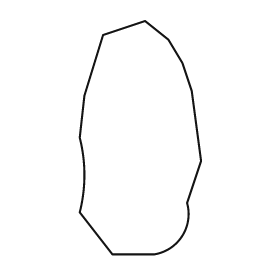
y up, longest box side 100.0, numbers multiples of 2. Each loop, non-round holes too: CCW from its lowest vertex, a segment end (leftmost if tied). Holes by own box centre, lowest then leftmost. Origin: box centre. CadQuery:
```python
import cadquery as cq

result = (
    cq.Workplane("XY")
    .moveTo(-12.0, -50.0)
    .lineTo(6.0, -50.0)
    .threePointArc((18.0, -42.0), (20.0, -28.0))
    .lineTo(26.0, -10.0)
    .lineTo(22.0, 20.0)
    .lineTo(18.0, 32.0)
    .lineTo(12.0, 42.0)
    .lineTo(2.0, 50.0)
    .lineTo(-16.0, 44.0)
    .lineTo(-24.0, 18.0)
    .lineTo(-26.0, 0.0)
    .threePointArc((-24.0, -16.0), (-26.0, -32.0))
    .close()
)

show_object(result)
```